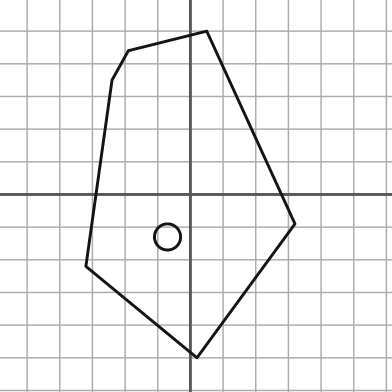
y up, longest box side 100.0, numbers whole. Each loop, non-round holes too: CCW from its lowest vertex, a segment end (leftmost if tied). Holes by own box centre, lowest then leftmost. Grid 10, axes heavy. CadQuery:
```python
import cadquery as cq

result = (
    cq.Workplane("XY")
    .moveTo(2.0, -50.0)
    .lineTo(32.0, -9.0)
    .lineTo(5.0, 50.0)
    .lineTo(-19.0, 44.0)
    .lineTo(-24.0, 35.0)
    .lineTo(-32.0, -22.0)
    .close()
    .moveTo(-7.0, -13.0)
    .circle(4.0)
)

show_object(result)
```